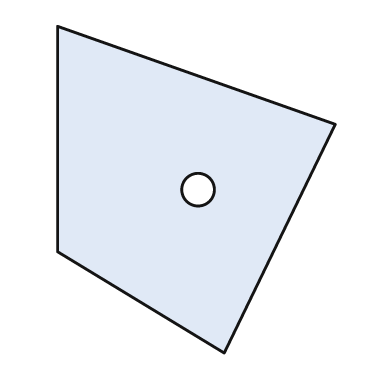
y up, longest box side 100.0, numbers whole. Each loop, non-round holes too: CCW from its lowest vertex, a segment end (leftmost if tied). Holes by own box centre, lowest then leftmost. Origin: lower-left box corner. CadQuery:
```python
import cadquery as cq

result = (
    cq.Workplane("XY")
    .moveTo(51.0, 0.0)
    .lineTo(85.0, 70.0)
    .lineTo(0.0, 100.0)
    .lineTo(0.0, 31.0)
    .close()
    .moveTo(43.0, 50.0)
    .circle(5.0)
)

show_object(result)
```